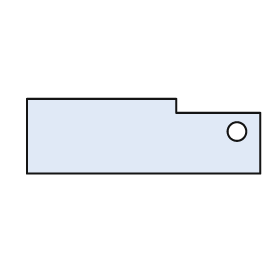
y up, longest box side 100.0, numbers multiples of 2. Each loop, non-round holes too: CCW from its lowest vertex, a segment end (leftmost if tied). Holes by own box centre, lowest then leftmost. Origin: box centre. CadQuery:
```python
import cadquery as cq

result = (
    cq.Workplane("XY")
    .moveTo(-50.0, -16.0)
    .lineTo(50.0, -16.0)
    .lineTo(50.0, 10.0)
    .lineTo(14.0, 10.0)
    .lineTo(14.0, 16.0)
    .lineTo(-50.0, 16.0)
    .close()
    .moveTo(40.0, 2.0)
    .circle(4.0)
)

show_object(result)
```